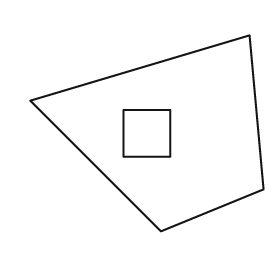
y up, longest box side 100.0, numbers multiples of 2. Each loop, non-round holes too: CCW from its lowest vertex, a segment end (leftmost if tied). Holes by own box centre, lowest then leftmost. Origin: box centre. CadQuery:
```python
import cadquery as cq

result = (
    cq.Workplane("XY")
    .moveTo(6.0, -42.0)
    .lineTo(50.0, -24.0)
    .lineTo(44.0, 42.0)
    .lineTo(-50.0, 14.0)
    .close()
    .moveTo(-10.0, -10.0)
    .lineTo(10.0, -10.0)
    .lineTo(10.0, 10.0)
    .lineTo(-10.0, 10.0)
    .close()
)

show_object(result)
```